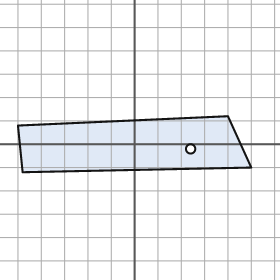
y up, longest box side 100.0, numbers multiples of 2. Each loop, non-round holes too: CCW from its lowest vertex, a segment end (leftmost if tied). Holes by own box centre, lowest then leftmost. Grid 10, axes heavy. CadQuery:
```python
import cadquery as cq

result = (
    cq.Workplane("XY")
    .moveTo(-48.0, -12.0)
    .lineTo(50.0, -10.0)
    .lineTo(40.0, 12.0)
    .lineTo(-50.0, 8.0)
    .close()
    .moveTo(24.0, -2.0)
    .circle(2.0)
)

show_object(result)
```